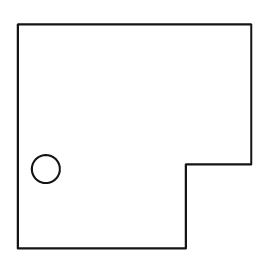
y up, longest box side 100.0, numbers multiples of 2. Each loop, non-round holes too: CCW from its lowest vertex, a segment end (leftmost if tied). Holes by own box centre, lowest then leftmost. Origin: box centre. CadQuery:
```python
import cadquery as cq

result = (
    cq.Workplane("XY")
    .moveTo(-50.0, -48.0)
    .lineTo(22.0, -48.0)
    .lineTo(22.0, -12.0)
    .lineTo(50.0, -12.0)
    .lineTo(50.0, 48.0)
    .lineTo(-50.0, 48.0)
    .close()
    .moveTo(-38.0, -14.0)
    .circle(6.0)
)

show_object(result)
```